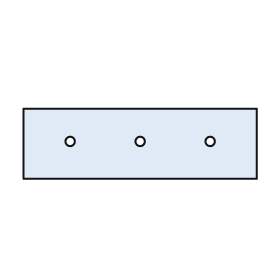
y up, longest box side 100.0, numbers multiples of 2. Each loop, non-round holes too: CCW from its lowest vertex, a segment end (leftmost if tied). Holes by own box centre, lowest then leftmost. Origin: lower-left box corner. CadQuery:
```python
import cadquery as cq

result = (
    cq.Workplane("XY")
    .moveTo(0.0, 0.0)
    .lineTo(100.0, 0.0)
    .lineTo(100.0, 30.0)
    .lineTo(0.0, 30.0)
    .close()
    .moveTo(20.0, 16.0)
    .circle(2.0)
    .moveTo(50.0, 16.0)
    .circle(2.0)
    .moveTo(80.0, 16.0)
    .circle(2.0)
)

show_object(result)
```